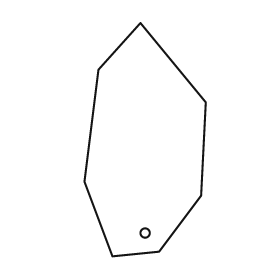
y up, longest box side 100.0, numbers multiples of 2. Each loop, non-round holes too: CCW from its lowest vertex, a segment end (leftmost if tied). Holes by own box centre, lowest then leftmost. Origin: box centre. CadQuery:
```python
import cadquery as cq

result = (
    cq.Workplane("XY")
    .moveTo(-14.0, -50.0)
    .lineTo(6.0, -48.0)
    .lineTo(24.0, -24.0)
    .lineTo(26.0, 16.0)
    .lineTo(-2.0, 50.0)
    .lineTo(-20.0, 30.0)
    .lineTo(-26.0, -18.0)
    .close()
    .moveTo(0.0, -40.0)
    .circle(2.0)
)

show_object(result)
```